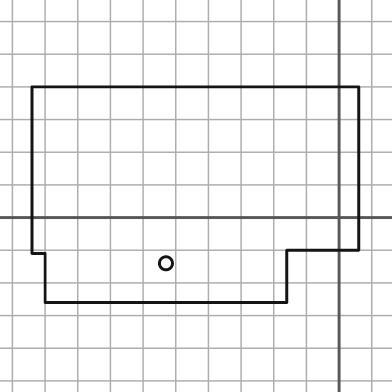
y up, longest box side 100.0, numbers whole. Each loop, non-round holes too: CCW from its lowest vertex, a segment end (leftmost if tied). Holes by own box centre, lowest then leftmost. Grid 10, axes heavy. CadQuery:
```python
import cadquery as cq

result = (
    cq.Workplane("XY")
    .moveTo(-90.0, -26.0)
    .lineTo(-16.0, -26.0)
    .lineTo(-16.0, -10.0)
    .lineTo(6.0, -10.0)
    .lineTo(6.0, 40.0)
    .lineTo(-94.0, 40.0)
    .lineTo(-94.0, -11.0)
    .lineTo(-90.0, -11.0)
    .close()
    .moveTo(-53.0, -14.0)
    .circle(2.0)
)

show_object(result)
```